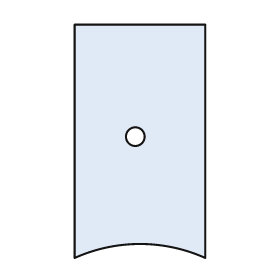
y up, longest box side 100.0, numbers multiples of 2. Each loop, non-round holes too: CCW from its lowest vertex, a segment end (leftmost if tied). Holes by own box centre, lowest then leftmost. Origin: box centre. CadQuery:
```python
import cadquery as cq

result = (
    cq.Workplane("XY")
    .moveTo(-28.0, -50.0)
    .threePointArc((0.0, -44.0), (28.0, -50.0))
    .lineTo(28.0, 50.0)
    .lineTo(-28.0, 50.0)
    .close()
    .moveTo(-2.0, 2.0)
    .circle(4.0)
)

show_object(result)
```